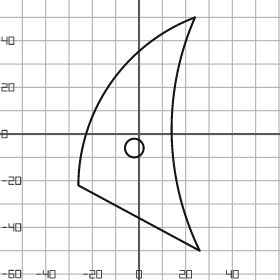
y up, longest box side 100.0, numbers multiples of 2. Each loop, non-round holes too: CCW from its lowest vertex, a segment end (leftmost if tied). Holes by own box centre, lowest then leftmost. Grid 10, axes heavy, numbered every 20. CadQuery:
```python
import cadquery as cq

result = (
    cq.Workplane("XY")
    .moveTo(26.0, -50.0)
    .threePointArc((14.0, 0.0), (24.0, 50.0))
    .threePointArc((-12.0, 22.0), (-26.0, -22.0))
    .close()
    .moveTo(-2.0, -6.0)
    .circle(4.0)
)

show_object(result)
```